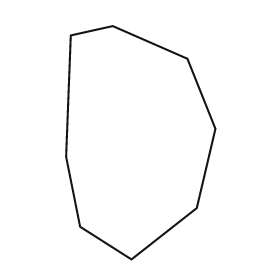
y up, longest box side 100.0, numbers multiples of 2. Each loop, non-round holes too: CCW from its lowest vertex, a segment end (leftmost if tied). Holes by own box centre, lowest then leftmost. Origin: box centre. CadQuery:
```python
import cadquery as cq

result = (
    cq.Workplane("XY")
    .moveTo(-4.0, -50.0)
    .lineTo(24.0, -28.0)
    .lineTo(32.0, 6.0)
    .lineTo(20.0, 36.0)
    .lineTo(-12.0, 50.0)
    .lineTo(-30.0, 46.0)
    .lineTo(-32.0, -6.0)
    .lineTo(-26.0, -36.0)
    .close()
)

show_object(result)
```